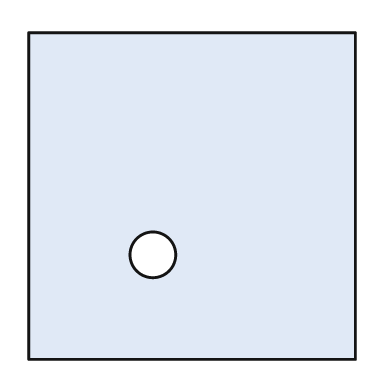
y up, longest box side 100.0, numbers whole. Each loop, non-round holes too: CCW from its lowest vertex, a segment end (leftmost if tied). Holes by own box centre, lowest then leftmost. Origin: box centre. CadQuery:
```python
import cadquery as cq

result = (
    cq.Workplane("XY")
    .moveTo(-50.0, -50.0)
    .lineTo(50.0, -50.0)
    .lineTo(50.0, 50.0)
    .lineTo(-50.0, 50.0)
    .close()
    .moveTo(-12.0, -18.0)
    .circle(7.0)
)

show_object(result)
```